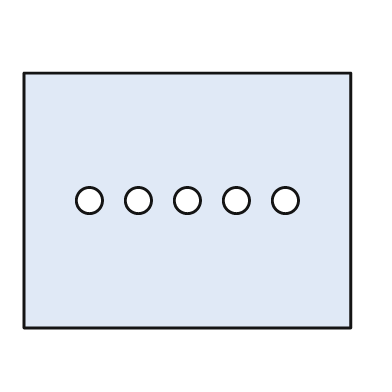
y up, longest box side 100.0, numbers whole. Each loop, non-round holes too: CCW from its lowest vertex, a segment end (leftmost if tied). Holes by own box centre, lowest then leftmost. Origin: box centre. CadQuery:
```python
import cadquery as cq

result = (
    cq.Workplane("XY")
    .moveTo(-50.0, -39.0)
    .lineTo(50.0, -39.0)
    .lineTo(50.0, 39.0)
    .lineTo(-50.0, 39.0)
    .close()
    .moveTo(-30.0, 0.0)
    .circle(4.0)
    .moveTo(-15.0, 0.0)
    .circle(4.0)
    .moveTo(0.0, 0.0)
    .circle(4.0)
    .moveTo(15.0, 0.0)
    .circle(4.0)
    .moveTo(30.0, 0.0)
    .circle(4.0)
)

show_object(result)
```